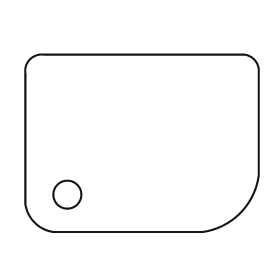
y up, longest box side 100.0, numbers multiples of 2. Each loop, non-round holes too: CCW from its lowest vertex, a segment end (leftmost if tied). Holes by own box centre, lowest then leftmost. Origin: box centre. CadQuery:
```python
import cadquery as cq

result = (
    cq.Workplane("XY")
    .moveTo(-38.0, -38.0)
    .lineTo(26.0, -38.0)
    .threePointArc((42.0, -30.0), (50.0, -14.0))
    .lineTo(50.0, 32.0)
    .threePointArc((48.0, 36.0), (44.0, 38.0))
    .lineTo(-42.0, 38.0)
    .threePointArc((-48.0, 36.0), (-50.0, 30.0))
    .lineTo(-50.0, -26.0)
    .threePointArc((-46.0, -34.0), (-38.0, -38.0))
    .close()
    .moveTo(-32.0, -22.0)
    .circle(6.0)
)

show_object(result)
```